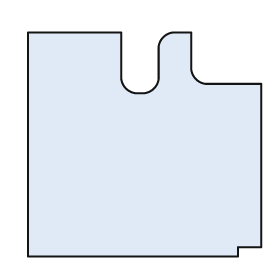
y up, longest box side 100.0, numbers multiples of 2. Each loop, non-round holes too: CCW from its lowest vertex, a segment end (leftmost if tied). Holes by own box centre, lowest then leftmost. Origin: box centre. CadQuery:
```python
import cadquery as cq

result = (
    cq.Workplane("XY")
    .moveTo(-50.0, -48.0)
    .lineTo(40.0, -48.0)
    .lineTo(40.0, -44.0)
    .lineTo(50.0, -44.0)
    .lineTo(50.0, 26.0)
    .lineTo(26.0, 26.0)
    .threePointArc((22.0, 28.0), (20.0, 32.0))
    .lineTo(20.0, 48.0)
    .lineTo(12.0, 48.0)
    .threePointArc((8.0, 46.0), (6.0, 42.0))
    .lineTo(6.0, 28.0)
    .threePointArc((4.0, 24.0), (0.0, 22.0))
    .lineTo(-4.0, 22.0)
    .threePointArc((-8.0, 24.0), (-10.0, 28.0))
    .lineTo(-10.0, 48.0)
    .lineTo(-50.0, 48.0)
    .close()
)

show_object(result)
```